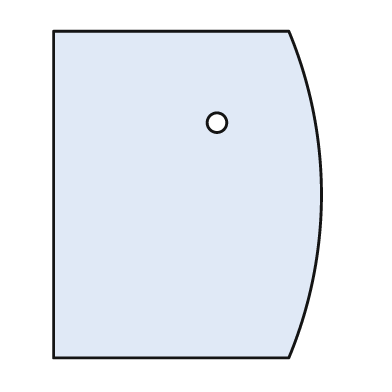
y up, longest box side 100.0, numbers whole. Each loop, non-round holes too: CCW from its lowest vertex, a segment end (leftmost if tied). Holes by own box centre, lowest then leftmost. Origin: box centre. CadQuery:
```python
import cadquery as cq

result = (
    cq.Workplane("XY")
    .moveTo(-41.0, -50.0)
    .lineTo(31.0, -50.0)
    .threePointArc((41.0, 0.0), (31.0, 50.0))
    .lineTo(-41.0, 50.0)
    .close()
    .moveTo(9.0, 22.0)
    .circle(3.0)
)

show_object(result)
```